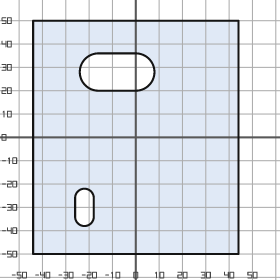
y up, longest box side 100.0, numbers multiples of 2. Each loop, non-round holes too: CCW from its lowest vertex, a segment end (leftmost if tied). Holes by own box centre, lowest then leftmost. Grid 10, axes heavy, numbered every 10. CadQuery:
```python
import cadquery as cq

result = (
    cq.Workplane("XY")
    .moveTo(-44.0, -50.0)
    .lineTo(44.0, -50.0)
    .lineTo(44.0, 50.0)
    .lineTo(-44.0, 50.0)
    .close()
    .moveTo(-26.0, -34.0)
    .threePointArc((-22.0, -38.0), (-18.0, -34.0))
    .lineTo(-18.0, -26.0)
    .threePointArc((-22.0, -22.0), (-26.0, -26.0))
    .close()
    .moveTo(-16.0, 20.0)
    .lineTo(0.0, 20.0)
    .threePointArc((8.0, 28.0), (0.0, 36.0))
    .lineTo(-16.0, 36.0)
    .threePointArc((-24.0, 28.0), (-16.0, 20.0))
    .close()
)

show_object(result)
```